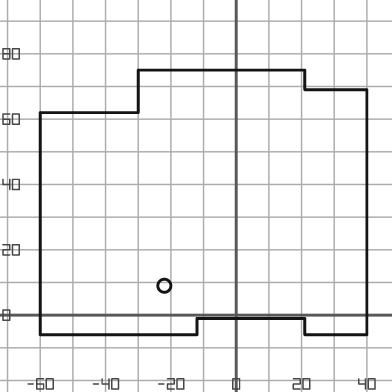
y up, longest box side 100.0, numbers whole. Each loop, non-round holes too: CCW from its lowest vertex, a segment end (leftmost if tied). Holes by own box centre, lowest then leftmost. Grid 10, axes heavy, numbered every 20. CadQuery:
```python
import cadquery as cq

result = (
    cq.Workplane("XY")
    .moveTo(-60.0, -6.0)
    .lineTo(-12.0, -6.0)
    .lineTo(-12.0, -1.0)
    .lineTo(21.0, -1.0)
    .lineTo(21.0, -6.0)
    .lineTo(40.0, -6.0)
    .lineTo(40.0, 69.0)
    .lineTo(21.0, 69.0)
    .lineTo(21.0, 75.0)
    .lineTo(-30.0, 75.0)
    .lineTo(-30.0, 62.0)
    .lineTo(-60.0, 62.0)
    .close()
    .moveTo(-22.0, 9.0)
    .circle(2.0)
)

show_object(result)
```